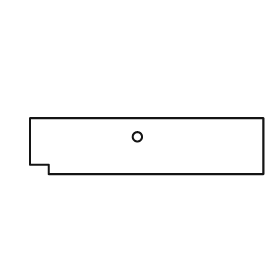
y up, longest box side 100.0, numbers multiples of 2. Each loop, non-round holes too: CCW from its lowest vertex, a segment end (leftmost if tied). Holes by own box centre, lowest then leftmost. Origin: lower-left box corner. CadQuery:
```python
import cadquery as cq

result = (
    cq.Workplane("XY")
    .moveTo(8.0, 0.0)
    .lineTo(100.0, 0.0)
    .lineTo(100.0, 24.0)
    .lineTo(0.0, 24.0)
    .lineTo(0.0, 4.0)
    .lineTo(8.0, 4.0)
    .close()
    .moveTo(46.0, 16.0)
    .circle(2.0)
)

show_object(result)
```